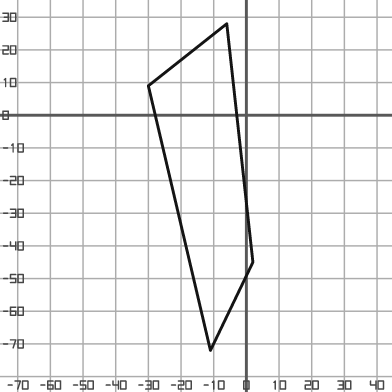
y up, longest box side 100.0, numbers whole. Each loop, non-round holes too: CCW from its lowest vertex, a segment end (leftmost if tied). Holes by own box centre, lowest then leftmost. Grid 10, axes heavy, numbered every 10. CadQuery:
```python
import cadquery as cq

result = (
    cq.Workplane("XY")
    .moveTo(-11.0, -72.0)
    .lineTo(2.0, -45.0)
    .lineTo(-6.0, 28.0)
    .lineTo(-30.0, 9.0)
    .close()
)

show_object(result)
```